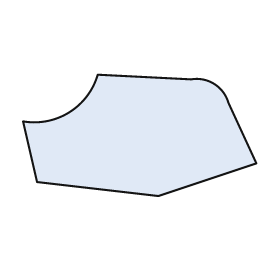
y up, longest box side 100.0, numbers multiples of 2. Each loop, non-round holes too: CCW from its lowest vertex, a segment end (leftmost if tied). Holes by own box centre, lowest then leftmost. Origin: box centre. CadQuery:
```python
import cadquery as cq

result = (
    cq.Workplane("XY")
    .moveTo(8.0, -26.0)
    .lineTo(50.0, -12.0)
    .lineTo(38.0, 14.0)
    .threePointArc((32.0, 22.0), (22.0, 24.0))
    .lineTo(-18.0, 26.0)
    .threePointArc((-30.0, 10.0), (-50.0, 6.0))
    .lineTo(-44.0, -20.0)
    .close()
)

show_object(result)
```